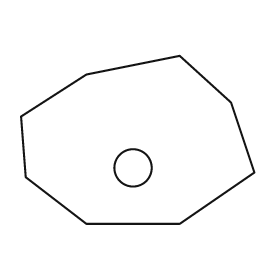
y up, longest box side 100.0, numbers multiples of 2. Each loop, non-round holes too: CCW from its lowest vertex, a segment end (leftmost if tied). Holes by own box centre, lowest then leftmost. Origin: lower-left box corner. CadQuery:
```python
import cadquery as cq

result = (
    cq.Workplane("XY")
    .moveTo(28.0, 0.0)
    .lineTo(68.0, 0.0)
    .lineTo(100.0, 22.0)
    .lineTo(90.0, 52.0)
    .lineTo(68.0, 72.0)
    .lineTo(28.0, 64.0)
    .lineTo(0.0, 46.0)
    .lineTo(2.0, 20.0)
    .close()
    .moveTo(48.0, 24.0)
    .circle(8.0)
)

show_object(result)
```